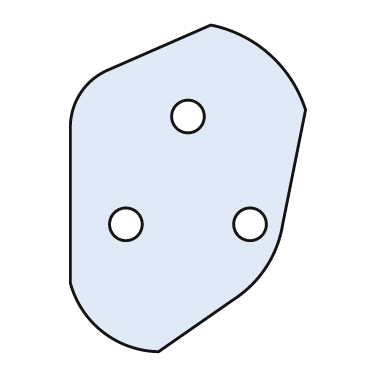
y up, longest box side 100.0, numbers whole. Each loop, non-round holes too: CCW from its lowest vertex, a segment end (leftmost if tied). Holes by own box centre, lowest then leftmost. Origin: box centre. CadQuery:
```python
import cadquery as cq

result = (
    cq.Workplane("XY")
    .moveTo(-9.0, -50.0)
    .lineTo(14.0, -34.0)
    .threePointArc((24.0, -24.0), (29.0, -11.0))
    .lineTo(36.0, 24.0)
    .threePointArc((25.0, 41.0), (7.0, 50.0))
    .lineTo(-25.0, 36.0)
    .threePointArc((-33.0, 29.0), (-36.0, 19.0))
    .lineTo(-36.0, -29.0)
    .threePointArc((-26.0, -44.0), (-9.0, -50.0))
    .close()
    .moveTo(-19.0, -11.0)
    .circle(5.0)
    .moveTo(19.0, -11.0)
    .circle(5.0)
    .moveTo(0.0, 22.0)
    .circle(5.0)
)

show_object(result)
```